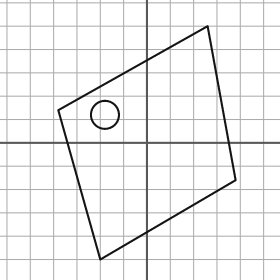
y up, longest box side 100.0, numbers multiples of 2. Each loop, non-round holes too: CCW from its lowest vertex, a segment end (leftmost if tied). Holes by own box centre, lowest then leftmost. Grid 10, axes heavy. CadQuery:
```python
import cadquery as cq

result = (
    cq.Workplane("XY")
    .moveTo(-20.0, -50.0)
    .lineTo(38.0, -16.0)
    .lineTo(26.0, 50.0)
    .lineTo(-38.0, 14.0)
    .close()
    .moveTo(-18.0, 12.0)
    .circle(6.0)
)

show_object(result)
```